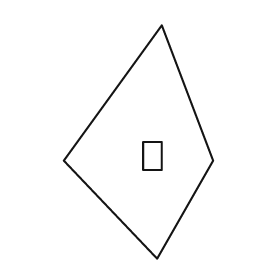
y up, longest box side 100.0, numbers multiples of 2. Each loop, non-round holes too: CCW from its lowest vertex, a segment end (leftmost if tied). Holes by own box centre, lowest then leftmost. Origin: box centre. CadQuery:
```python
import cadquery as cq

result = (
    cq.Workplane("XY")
    .moveTo(8.0, -50.0)
    .lineTo(32.0, -8.0)
    .lineTo(10.0, 50.0)
    .lineTo(-32.0, -8.0)
    .close()
    .moveTo(2.0, -12.0)
    .lineTo(10.0, -12.0)
    .lineTo(10.0, 0.0)
    .lineTo(2.0, 0.0)
    .close()
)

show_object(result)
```